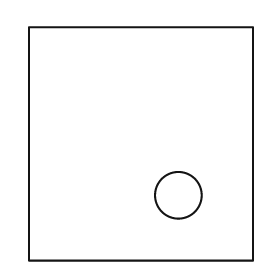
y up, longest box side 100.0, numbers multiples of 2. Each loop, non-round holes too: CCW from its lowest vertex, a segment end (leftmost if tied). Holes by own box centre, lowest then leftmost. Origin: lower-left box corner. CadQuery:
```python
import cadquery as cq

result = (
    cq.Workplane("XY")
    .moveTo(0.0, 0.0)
    .lineTo(96.0, 0.0)
    .lineTo(96.0, 100.0)
    .lineTo(0.0, 100.0)
    .close()
    .moveTo(64.0, 28.0)
    .circle(10.0)
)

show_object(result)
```